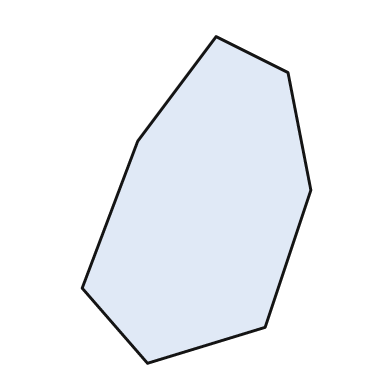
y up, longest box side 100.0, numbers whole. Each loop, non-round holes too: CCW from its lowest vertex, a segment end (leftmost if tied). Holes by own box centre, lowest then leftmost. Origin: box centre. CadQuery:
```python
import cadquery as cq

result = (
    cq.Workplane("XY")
    .moveTo(-15.0, -50.0)
    .lineTo(21.0, -39.0)
    .lineTo(35.0, 3.0)
    .lineTo(28.0, 39.0)
    .lineTo(6.0, 50.0)
    .lineTo(-18.0, 18.0)
    .lineTo(-35.0, -27.0)
    .close()
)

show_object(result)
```